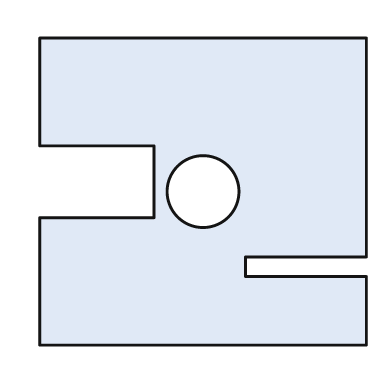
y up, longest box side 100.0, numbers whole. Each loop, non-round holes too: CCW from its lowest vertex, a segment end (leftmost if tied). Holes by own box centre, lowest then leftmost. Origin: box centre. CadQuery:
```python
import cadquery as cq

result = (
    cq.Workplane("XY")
    .moveTo(-50.0, -47.0)
    .lineTo(50.0, -47.0)
    .lineTo(50.0, -26.0)
    .lineTo(13.0, -26.0)
    .lineTo(13.0, -20.0)
    .lineTo(50.0, -20.0)
    .lineTo(50.0, 47.0)
    .lineTo(-50.0, 47.0)
    .lineTo(-50.0, 14.0)
    .lineTo(-15.0, 14.0)
    .lineTo(-15.0, -8.0)
    .lineTo(-50.0, -8.0)
    .close()
    .moveTo(0.0, 0.0)
    .circle(11.0)
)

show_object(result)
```